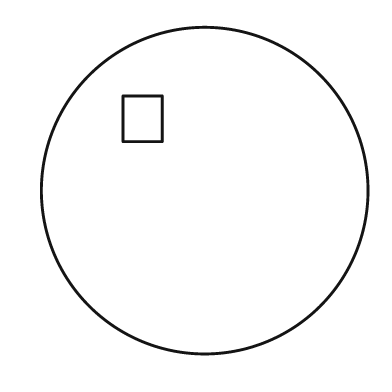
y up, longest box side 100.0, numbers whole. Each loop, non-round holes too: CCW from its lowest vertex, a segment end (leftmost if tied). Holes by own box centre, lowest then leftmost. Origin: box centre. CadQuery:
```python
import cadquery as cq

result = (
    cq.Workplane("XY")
    .moveTo(0.0, 0.0)
    .circle(50.0)
    .moveTo(-25.0, 15.0)
    .lineTo(-13.0, 15.0)
    .lineTo(-13.0, 29.0)
    .lineTo(-25.0, 29.0)
    .close()
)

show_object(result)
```